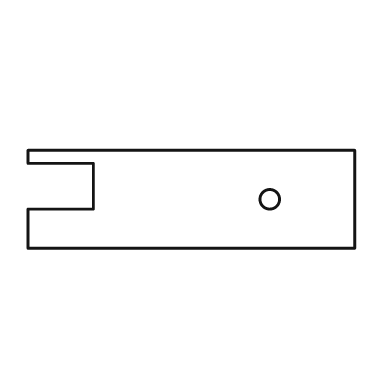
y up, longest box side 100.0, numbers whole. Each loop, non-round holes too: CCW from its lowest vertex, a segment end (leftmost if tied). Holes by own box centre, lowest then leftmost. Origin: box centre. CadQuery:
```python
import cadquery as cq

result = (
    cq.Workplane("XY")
    .moveTo(-50.0, -15.0)
    .lineTo(50.0, -15.0)
    .lineTo(50.0, 15.0)
    .lineTo(-50.0, 15.0)
    .lineTo(-50.0, 11.0)
    .lineTo(-30.0, 11.0)
    .lineTo(-30.0, -3.0)
    .lineTo(-50.0, -3.0)
    .close()
    .moveTo(24.0, 0.0)
    .circle(3.0)
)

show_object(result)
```